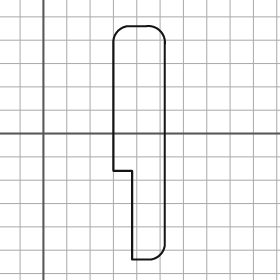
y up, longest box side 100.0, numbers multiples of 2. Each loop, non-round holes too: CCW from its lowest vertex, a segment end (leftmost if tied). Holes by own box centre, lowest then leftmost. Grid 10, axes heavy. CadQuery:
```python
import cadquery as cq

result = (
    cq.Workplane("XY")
    .moveTo(38.0, -54.0)
    .lineTo(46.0, -54.0)
    .threePointArc((50.0, -52.0), (52.0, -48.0))
    .lineTo(52.0, 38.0)
    .threePointArc((50.0, 44.0), (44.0, 46.0))
    .lineTo(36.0, 46.0)
    .threePointArc((32.0, 44.0), (30.0, 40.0))
    .lineTo(30.0, -16.0)
    .lineTo(38.0, -16.0)
    .close()
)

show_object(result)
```